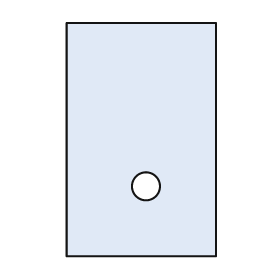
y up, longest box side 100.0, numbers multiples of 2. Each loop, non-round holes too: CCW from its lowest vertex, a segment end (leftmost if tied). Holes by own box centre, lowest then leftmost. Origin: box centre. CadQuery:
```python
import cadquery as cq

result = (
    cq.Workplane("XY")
    .moveTo(-32.0, -50.0)
    .lineTo(32.0, -50.0)
    .lineTo(32.0, 50.0)
    .lineTo(-32.0, 50.0)
    .close()
    .moveTo(2.0, -20.0)
    .circle(6.0)
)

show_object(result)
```